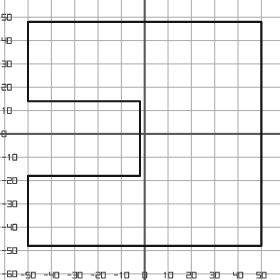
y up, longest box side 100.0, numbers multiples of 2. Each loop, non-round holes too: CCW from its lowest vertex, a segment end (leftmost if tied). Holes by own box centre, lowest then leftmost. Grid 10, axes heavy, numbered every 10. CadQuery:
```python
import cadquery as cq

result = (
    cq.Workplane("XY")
    .moveTo(-50.0, -48.0)
    .lineTo(50.0, -48.0)
    .lineTo(50.0, 48.0)
    .lineTo(-50.0, 48.0)
    .lineTo(-50.0, 14.0)
    .lineTo(-2.0, 14.0)
    .lineTo(-2.0, -18.0)
    .lineTo(-50.0, -18.0)
    .close()
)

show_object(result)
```